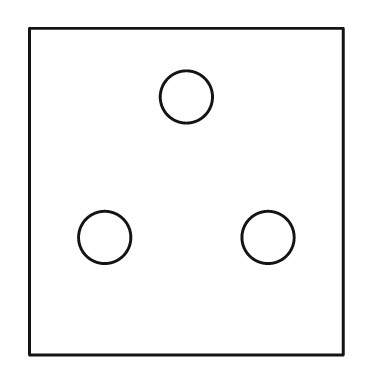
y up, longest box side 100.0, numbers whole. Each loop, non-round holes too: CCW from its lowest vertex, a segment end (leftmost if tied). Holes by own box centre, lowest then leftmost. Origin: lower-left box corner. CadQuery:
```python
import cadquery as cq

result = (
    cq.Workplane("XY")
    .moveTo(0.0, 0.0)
    .lineTo(96.0, 0.0)
    .lineTo(96.0, 100.0)
    .lineTo(0.0, 100.0)
    .close()
    .moveTo(23.0, 36.0)
    .circle(8.0)
    .moveTo(73.0, 36.0)
    .circle(8.0)
    .moveTo(48.0, 79.0)
    .circle(8.0)
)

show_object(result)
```